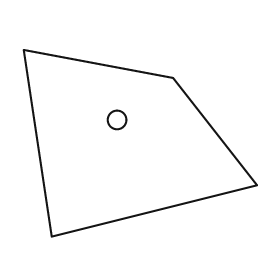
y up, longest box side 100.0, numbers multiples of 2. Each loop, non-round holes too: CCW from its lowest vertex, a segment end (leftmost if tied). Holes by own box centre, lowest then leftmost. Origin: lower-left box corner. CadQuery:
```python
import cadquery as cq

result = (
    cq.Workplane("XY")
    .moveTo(12.0, 0.0)
    .lineTo(100.0, 22.0)
    .lineTo(64.0, 68.0)
    .lineTo(0.0, 80.0)
    .close()
    .moveTo(40.0, 50.0)
    .circle(4.0)
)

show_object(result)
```